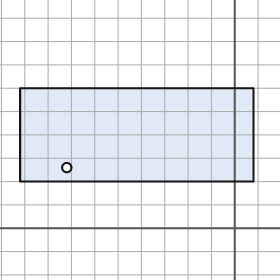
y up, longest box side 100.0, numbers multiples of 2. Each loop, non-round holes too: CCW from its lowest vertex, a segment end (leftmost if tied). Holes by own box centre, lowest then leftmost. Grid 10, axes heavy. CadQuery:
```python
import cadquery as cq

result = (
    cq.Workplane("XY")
    .moveTo(-92.0, 20.0)
    .lineTo(8.0, 20.0)
    .lineTo(8.0, 60.0)
    .lineTo(-92.0, 60.0)
    .close()
    .moveTo(-72.0, 26.0)
    .circle(2.0)
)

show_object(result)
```